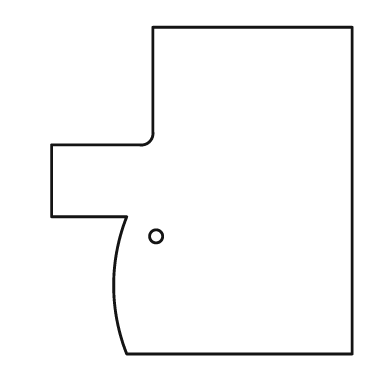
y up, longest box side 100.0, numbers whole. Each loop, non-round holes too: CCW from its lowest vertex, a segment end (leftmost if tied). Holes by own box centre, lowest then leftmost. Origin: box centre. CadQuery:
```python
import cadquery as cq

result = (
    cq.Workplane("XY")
    .moveTo(-23.0, -50.0)
    .lineTo(46.0, -50.0)
    .lineTo(46.0, 50.0)
    .lineTo(-15.0, 50.0)
    .lineTo(-15.0, 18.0)
    .threePointArc((-16.0, 15.0), (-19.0, 14.0))
    .lineTo(-46.0, 14.0)
    .lineTo(-46.0, -8.0)
    .lineTo(-23.0, -8.0)
    .threePointArc((-27.0, -29.0), (-23.0, -50.0))
    .close()
    .moveTo(-14.0, -14.0)
    .circle(2.0)
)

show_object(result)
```